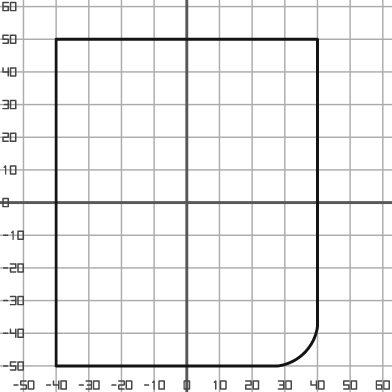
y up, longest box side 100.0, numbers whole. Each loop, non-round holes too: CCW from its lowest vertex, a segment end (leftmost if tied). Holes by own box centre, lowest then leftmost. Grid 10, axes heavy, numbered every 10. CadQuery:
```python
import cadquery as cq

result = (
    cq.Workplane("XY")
    .moveTo(-40.0, -50.0)
    .lineTo(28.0, -50.0)
    .threePointArc((36.0, -46.0), (40.0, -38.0))
    .lineTo(40.0, 50.0)
    .lineTo(-40.0, 50.0)
    .close()
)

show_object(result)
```